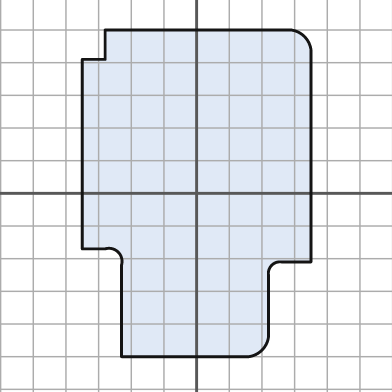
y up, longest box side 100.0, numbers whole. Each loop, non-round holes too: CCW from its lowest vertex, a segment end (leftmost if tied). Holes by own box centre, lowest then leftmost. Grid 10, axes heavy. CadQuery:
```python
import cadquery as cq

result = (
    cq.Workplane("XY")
    .moveTo(-23.0, -50.0)
    .lineTo(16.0, -50.0)
    .threePointArc((20.0, -48.0), (22.0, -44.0))
    .lineTo(22.0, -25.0)
    .threePointArc((23.0, -22.0), (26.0, -21.0))
    .lineTo(35.0, -21.0)
    .lineTo(35.0, 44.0)
    .threePointArc((33.0, 48.0), (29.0, 50.0))
    .lineTo(-28.0, 50.0)
    .lineTo(-28.0, 41.0)
    .lineTo(-35.0, 41.0)
    .lineTo(-35.0, -17.0)
    .lineTo(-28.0, -17.0)
    .threePointArc((-24.0, -18.0), (-23.0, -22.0))
    .close()
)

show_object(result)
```